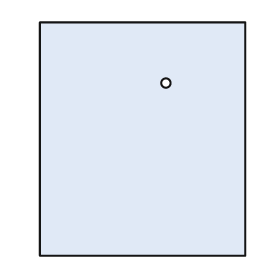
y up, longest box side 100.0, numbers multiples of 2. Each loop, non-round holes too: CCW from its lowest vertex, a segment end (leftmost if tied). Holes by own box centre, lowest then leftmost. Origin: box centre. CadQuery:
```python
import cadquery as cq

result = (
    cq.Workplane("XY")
    .moveTo(-44.0, -50.0)
    .lineTo(44.0, -50.0)
    .lineTo(44.0, 50.0)
    .lineTo(-44.0, 50.0)
    .close()
    .moveTo(10.0, 24.0)
    .circle(2.0)
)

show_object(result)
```